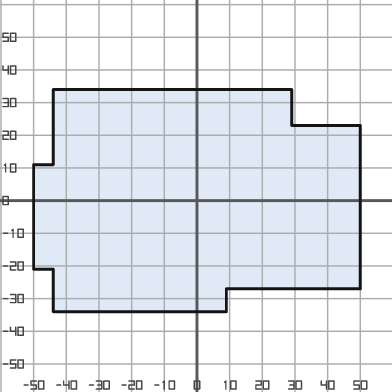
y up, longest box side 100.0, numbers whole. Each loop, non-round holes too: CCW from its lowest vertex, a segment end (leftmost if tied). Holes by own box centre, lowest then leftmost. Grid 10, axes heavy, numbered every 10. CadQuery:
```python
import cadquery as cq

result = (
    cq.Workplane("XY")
    .moveTo(-44.0, -34.0)
    .lineTo(9.0, -34.0)
    .lineTo(9.0, -27.0)
    .lineTo(50.0, -27.0)
    .lineTo(50.0, 23.0)
    .lineTo(29.0, 23.0)
    .lineTo(29.0, 34.0)
    .lineTo(-44.0, 34.0)
    .lineTo(-44.0, 11.0)
    .lineTo(-50.0, 11.0)
    .lineTo(-50.0, -21.0)
    .lineTo(-44.0, -21.0)
    .close()
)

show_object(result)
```